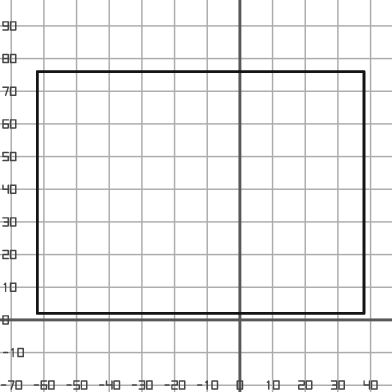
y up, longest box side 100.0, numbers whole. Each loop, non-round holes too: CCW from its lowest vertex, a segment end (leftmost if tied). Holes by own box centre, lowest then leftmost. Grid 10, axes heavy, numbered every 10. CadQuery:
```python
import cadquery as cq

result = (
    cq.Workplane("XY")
    .moveTo(-62.0, 2.0)
    .lineTo(38.0, 2.0)
    .lineTo(38.0, 76.0)
    .lineTo(-62.0, 76.0)
    .close()
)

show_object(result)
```